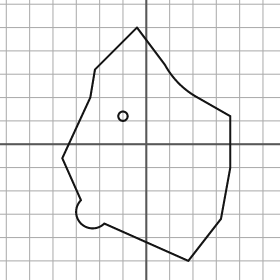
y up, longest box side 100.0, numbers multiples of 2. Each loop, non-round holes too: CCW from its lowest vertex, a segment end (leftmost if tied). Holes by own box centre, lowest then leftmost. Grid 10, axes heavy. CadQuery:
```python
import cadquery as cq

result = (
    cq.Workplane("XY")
    .moveTo(18.0, -50.0)
    .lineTo(32.0, -32.0)
    .lineTo(36.0, -10.0)
    .lineTo(36.0, 12.0)
    .lineTo(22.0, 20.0)
    .threePointArc((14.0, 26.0), (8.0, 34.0))
    .lineTo(-4.0, 50.0)
    .lineTo(-22.0, 32.0)
    .lineTo(-24.0, 20.0)
    .lineTo(-36.0, -6.0)
    .lineTo(-28.0, -24.0)
    .threePointArc((-28.0, -34.0), (-18.0, -34.0))
    .close()
    .moveTo(-10.0, 12.0)
    .circle(2.0)
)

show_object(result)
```